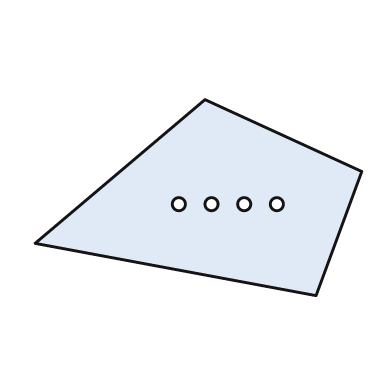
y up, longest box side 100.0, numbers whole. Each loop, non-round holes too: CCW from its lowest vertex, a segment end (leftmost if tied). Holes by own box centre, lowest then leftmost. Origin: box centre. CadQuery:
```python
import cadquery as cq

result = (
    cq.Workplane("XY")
    .moveTo(36.0, -30.0)
    .lineTo(50.0, 8.0)
    .lineTo(2.0, 30.0)
    .lineTo(-50.0, -14.0)
    .close()
    .moveTo(-6.0, -2.0)
    .circle(2.0)
    .moveTo(4.0, -2.0)
    .circle(2.0)
    .moveTo(14.0, -2.0)
    .circle(2.0)
    .moveTo(24.0, -2.0)
    .circle(2.0)
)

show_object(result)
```